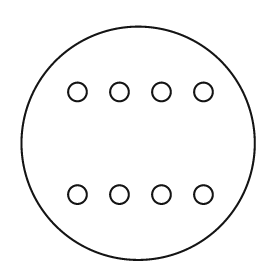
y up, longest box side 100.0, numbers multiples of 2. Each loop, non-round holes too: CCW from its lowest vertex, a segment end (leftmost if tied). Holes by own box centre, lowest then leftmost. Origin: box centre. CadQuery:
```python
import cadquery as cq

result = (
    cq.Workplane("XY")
    .moveTo(0.0, 0.0)
    .circle(50.0)
    .moveTo(-26.0, -22.0)
    .circle(4.0)
    .moveTo(-8.0, -22.0)
    .circle(4.0)
    .moveTo(10.0, -22.0)
    .circle(4.0)
    .moveTo(28.0, -22.0)
    .circle(4.0)
    .moveTo(-26.0, 22.0)
    .circle(4.0)
    .moveTo(-8.0, 22.0)
    .circle(4.0)
    .moveTo(10.0, 22.0)
    .circle(4.0)
    .moveTo(28.0, 22.0)
    .circle(4.0)
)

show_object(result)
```